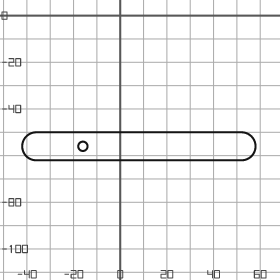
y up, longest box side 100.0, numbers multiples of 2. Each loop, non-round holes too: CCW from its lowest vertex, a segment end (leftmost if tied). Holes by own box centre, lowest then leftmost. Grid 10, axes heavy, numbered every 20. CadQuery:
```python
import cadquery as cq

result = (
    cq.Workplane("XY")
    .moveTo(-36.0, -62.0)
    .lineTo(52.0, -62.0)
    .threePointArc((58.0, -56.0), (52.0, -50.0))
    .lineTo(-36.0, -50.0)
    .threePointArc((-42.0, -56.0), (-36.0, -62.0))
    .close()
    .moveTo(-16.0, -56.0)
    .circle(2.0)
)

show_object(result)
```